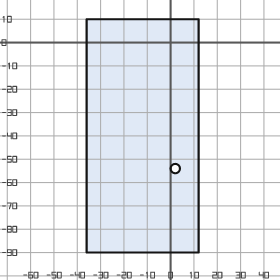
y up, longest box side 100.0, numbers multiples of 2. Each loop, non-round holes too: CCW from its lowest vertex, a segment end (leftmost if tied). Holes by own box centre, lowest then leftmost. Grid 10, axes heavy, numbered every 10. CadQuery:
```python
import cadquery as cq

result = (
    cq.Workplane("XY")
    .moveTo(-36.0, -90.0)
    .lineTo(12.0, -90.0)
    .lineTo(12.0, 10.0)
    .lineTo(-36.0, 10.0)
    .close()
    .moveTo(2.0, -54.0)
    .circle(2.0)
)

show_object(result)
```